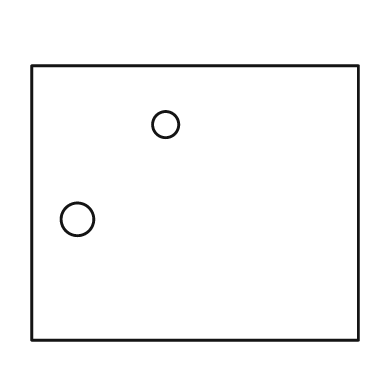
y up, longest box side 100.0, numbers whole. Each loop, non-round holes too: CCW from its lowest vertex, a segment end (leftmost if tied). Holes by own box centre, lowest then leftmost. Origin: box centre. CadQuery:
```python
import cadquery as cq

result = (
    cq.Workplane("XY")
    .moveTo(-50.0, -42.0)
    .lineTo(50.0, -42.0)
    .lineTo(50.0, 42.0)
    .lineTo(-50.0, 42.0)
    .close()
    .moveTo(-36.0, -5.0)
    .circle(5.0)
    .moveTo(-9.0, 24.0)
    .circle(4.0)
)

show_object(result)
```